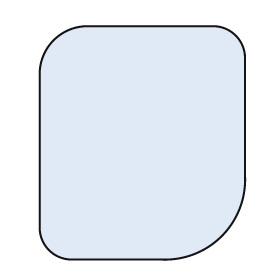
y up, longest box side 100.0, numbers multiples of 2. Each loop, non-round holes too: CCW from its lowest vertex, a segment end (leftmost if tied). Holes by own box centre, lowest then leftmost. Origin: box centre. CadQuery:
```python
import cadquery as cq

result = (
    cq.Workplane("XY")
    .moveTo(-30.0, -50.0)
    .lineTo(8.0, -50.0)
    .threePointArc((34.0, -40.0), (44.0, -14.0))
    .lineTo(44.0, 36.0)
    .threePointArc((40.0, 46.0), (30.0, 50.0))
    .lineTo(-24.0, 50.0)
    .threePointArc((-38.0, 44.0), (-44.0, 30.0))
    .lineTo(-44.0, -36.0)
    .threePointArc((-40.0, -46.0), (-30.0, -50.0))
    .close()
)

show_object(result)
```